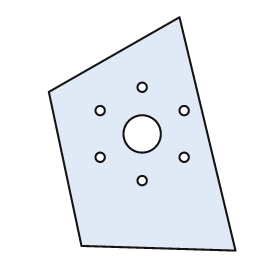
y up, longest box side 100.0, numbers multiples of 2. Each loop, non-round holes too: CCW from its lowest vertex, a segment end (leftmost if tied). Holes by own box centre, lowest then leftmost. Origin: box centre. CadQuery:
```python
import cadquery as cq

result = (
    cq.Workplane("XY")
    .moveTo(40.0, -50.0)
    .lineTo(16.0, 50.0)
    .lineTo(-40.0, 18.0)
    .lineTo(-26.0, -48.0)
    .close()
    .moveTo(0.0, -20.0)
    .circle(2.0)
    .moveTo(-18.0, -10.0)
    .circle(2.0)
    .moveTo(18.0, -10.0)
    .circle(2.0)
    .moveTo(0.0, 0.0)
    .circle(8.0)
    .moveTo(-18.0, 10.0)
    .circle(2.0)
    .moveTo(18.0, 10.0)
    .circle(2.0)
    .moveTo(0.0, 20.0)
    .circle(2.0)
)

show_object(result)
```